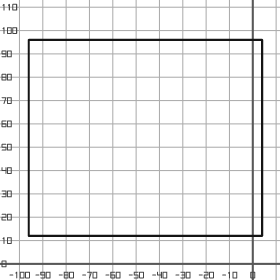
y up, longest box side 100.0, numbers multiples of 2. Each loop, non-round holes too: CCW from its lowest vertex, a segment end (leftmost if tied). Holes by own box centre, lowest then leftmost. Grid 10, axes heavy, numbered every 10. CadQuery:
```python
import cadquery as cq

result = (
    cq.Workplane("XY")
    .moveTo(-96.0, 12.0)
    .lineTo(4.0, 12.0)
    .lineTo(4.0, 96.0)
    .lineTo(-96.0, 96.0)
    .close()
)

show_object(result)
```